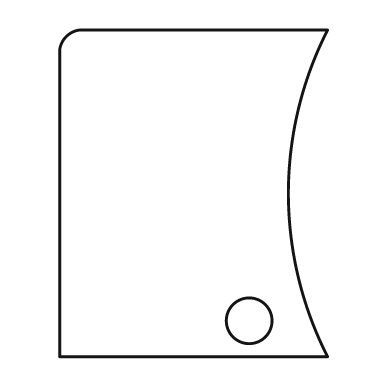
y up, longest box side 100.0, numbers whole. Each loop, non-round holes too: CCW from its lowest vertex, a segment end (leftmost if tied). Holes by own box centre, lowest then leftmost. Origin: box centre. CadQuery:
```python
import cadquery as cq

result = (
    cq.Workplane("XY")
    .moveTo(-41.0, -50.0)
    .lineTo(41.0, -50.0)
    .threePointArc((29.0, 0.0), (41.0, 50.0))
    .lineTo(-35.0, 50.0)
    .threePointArc((-39.0, 48.0), (-41.0, 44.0))
    .close()
    .moveTo(17.0, -39.0)
    .circle(7.0)
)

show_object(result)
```